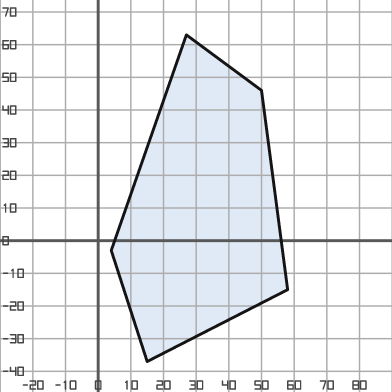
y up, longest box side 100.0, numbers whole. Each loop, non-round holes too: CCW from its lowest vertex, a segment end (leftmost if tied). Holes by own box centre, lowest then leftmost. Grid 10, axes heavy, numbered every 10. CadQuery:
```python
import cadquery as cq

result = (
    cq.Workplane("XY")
    .moveTo(15.0, -37.0)
    .lineTo(58.0, -15.0)
    .lineTo(50.0, 46.0)
    .lineTo(27.0, 63.0)
    .lineTo(4.0, -3.0)
    .close()
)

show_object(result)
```